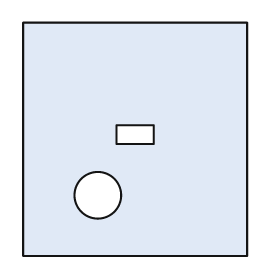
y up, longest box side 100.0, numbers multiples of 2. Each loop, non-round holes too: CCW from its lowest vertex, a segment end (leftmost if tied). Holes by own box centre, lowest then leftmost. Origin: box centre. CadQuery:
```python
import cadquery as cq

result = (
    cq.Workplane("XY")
    .moveTo(-48.0, -50.0)
    .lineTo(48.0, -50.0)
    .lineTo(48.0, 50.0)
    .lineTo(-48.0, 50.0)
    .close()
    .moveTo(-16.0, -24.0)
    .circle(10.0)
    .moveTo(-8.0, -2.0)
    .lineTo(8.0, -2.0)
    .lineTo(8.0, 6.0)
    .lineTo(-8.0, 6.0)
    .close()
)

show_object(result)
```